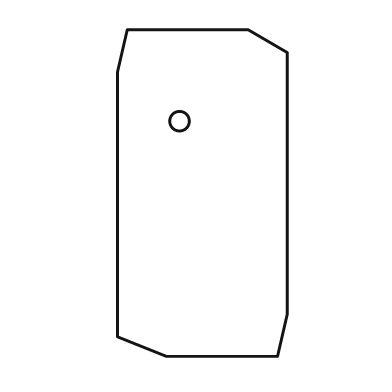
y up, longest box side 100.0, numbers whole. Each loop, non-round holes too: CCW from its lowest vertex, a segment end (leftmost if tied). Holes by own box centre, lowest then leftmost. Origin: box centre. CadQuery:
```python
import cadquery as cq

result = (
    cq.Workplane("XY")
    .moveTo(-11.0, -50.0)
    .lineTo(23.0, -50.0)
    .lineTo(26.0, -37.0)
    .lineTo(26.0, 43.0)
    .lineTo(14.0, 50.0)
    .lineTo(-23.0, 50.0)
    .lineTo(-26.0, 37.0)
    .lineTo(-26.0, -44.0)
    .close()
    .moveTo(-7.0, 22.0)
    .circle(3.0)
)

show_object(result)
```